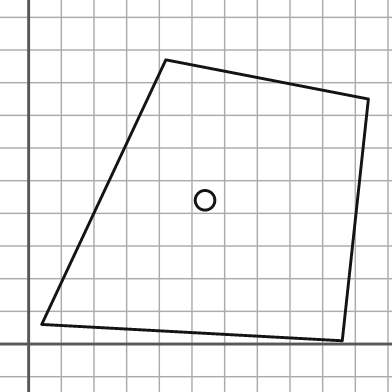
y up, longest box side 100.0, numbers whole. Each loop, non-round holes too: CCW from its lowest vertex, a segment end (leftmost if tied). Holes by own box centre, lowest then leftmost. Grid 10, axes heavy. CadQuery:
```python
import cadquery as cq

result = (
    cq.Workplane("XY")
    .moveTo(96.0, 1.0)
    .lineTo(104.0, 75.0)
    .lineTo(42.0, 87.0)
    .lineTo(4.0, 6.0)
    .close()
    .moveTo(54.0, 44.0)
    .circle(3.0)
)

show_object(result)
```